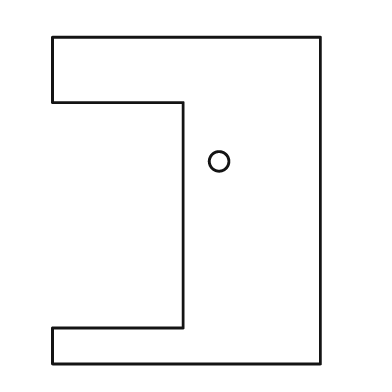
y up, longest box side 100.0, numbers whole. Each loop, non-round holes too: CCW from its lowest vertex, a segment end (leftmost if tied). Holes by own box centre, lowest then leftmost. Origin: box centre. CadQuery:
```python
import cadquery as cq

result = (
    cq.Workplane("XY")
    .moveTo(-41.0, -50.0)
    .lineTo(41.0, -50.0)
    .lineTo(41.0, 50.0)
    .lineTo(-41.0, 50.0)
    .lineTo(-41.0, 30.0)
    .lineTo(-1.0, 30.0)
    .lineTo(-1.0, -39.0)
    .lineTo(-41.0, -39.0)
    .close()
    .moveTo(10.0, 12.0)
    .circle(3.0)
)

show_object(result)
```